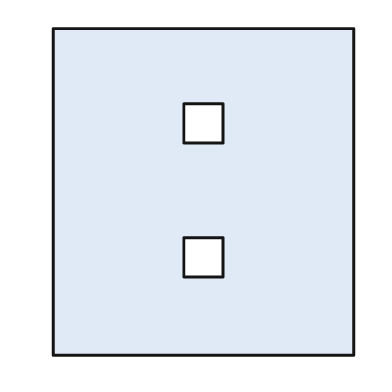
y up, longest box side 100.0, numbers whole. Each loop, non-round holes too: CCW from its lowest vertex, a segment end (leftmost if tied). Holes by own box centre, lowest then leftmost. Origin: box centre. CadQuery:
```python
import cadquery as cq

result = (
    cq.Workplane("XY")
    .moveTo(-46.0, -50.0)
    .lineTo(46.0, -50.0)
    .lineTo(46.0, 50.0)
    .lineTo(-46.0, 50.0)
    .close()
    .moveTo(-6.0, -26.0)
    .lineTo(6.0, -26.0)
    .lineTo(6.0, -14.0)
    .lineTo(-6.0, -14.0)
    .close()
    .moveTo(-6.0, 15.0)
    .lineTo(6.0, 15.0)
    .lineTo(6.0, 27.0)
    .lineTo(-6.0, 27.0)
    .close()
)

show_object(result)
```